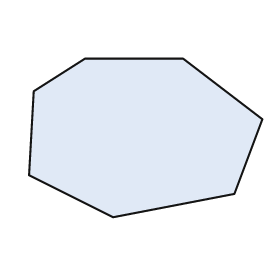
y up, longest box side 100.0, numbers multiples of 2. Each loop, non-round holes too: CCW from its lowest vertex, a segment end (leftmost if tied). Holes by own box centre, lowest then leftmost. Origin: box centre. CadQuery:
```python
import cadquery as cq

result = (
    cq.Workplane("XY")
    .moveTo(-14.0, -34.0)
    .lineTo(38.0, -24.0)
    .lineTo(50.0, 8.0)
    .lineTo(16.0, 34.0)
    .lineTo(-26.0, 34.0)
    .lineTo(-48.0, 20.0)
    .lineTo(-50.0, -16.0)
    .close()
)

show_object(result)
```